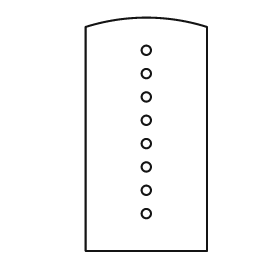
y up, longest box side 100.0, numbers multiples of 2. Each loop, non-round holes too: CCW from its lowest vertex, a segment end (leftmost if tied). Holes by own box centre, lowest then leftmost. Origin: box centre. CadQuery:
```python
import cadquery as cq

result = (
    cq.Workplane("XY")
    .moveTo(-26.0, -50.0)
    .lineTo(26.0, -50.0)
    .lineTo(26.0, 46.0)
    .threePointArc((0.0, 50.0), (-26.0, 46.0))
    .close()
    .moveTo(0.0, -34.0)
    .circle(2.0)
    .moveTo(0.0, -24.0)
    .circle(2.0)
    .moveTo(0.0, -14.0)
    .circle(2.0)
    .moveTo(0.0, -4.0)
    .circle(2.0)
    .moveTo(0.0, 6.0)
    .circle(2.0)
    .moveTo(0.0, 16.0)
    .circle(2.0)
    .moveTo(0.0, 26.0)
    .circle(2.0)
    .moveTo(0.0, 36.0)
    .circle(2.0)
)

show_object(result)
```